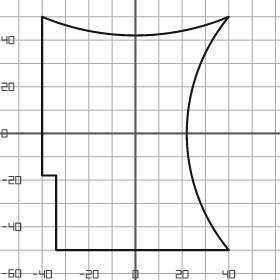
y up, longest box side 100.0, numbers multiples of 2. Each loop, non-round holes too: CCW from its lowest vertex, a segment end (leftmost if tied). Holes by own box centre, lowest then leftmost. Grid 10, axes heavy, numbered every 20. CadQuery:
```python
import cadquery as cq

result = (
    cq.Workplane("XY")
    .moveTo(-34.0, -50.0)
    .lineTo(40.0, -50.0)
    .threePointArc((22.0, 0.0), (40.0, 50.0))
    .threePointArc((0.0, 42.0), (-40.0, 50.0))
    .lineTo(-40.0, -18.0)
    .lineTo(-34.0, -18.0)
    .close()
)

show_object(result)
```